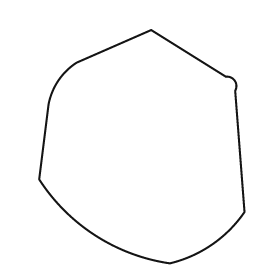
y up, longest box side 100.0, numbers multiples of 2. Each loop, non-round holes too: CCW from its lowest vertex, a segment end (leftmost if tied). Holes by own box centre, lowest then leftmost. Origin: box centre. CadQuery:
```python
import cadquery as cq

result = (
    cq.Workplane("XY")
    .moveTo(12.0, -50.0)
    .threePointArc((30.0, -42.0), (44.0, -28.0))
    .lineTo(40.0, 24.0)
    .threePointArc((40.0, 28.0), (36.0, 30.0))
    .lineTo(4.0, 50.0)
    .lineTo(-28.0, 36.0)
    .threePointArc((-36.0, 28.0), (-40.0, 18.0))
    .lineTo(-44.0, -14.0)
    .threePointArc((-20.0, -38.0), (12.0, -50.0))
    .close()
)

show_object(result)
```